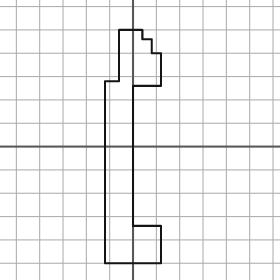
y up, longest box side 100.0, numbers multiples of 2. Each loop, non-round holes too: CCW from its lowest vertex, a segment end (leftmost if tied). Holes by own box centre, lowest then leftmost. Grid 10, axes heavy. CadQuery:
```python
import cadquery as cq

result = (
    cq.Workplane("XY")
    .moveTo(-12.0, -50.0)
    .lineTo(12.0, -50.0)
    .lineTo(12.0, -34.0)
    .lineTo(0.0, -34.0)
    .lineTo(0.0, 26.0)
    .lineTo(12.0, 26.0)
    .lineTo(12.0, 40.0)
    .lineTo(8.0, 40.0)
    .lineTo(8.0, 46.0)
    .lineTo(4.0, 46.0)
    .lineTo(4.0, 50.0)
    .lineTo(-6.0, 50.0)
    .lineTo(-6.0, 28.0)
    .lineTo(-12.0, 28.0)
    .close()
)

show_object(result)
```